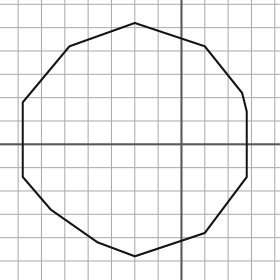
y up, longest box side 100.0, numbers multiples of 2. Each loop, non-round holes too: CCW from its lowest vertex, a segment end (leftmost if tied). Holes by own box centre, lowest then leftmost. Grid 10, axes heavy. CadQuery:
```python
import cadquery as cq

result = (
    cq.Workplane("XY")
    .moveTo(-20.0, -48.0)
    .lineTo(10.0, -38.0)
    .lineTo(28.0, -14.0)
    .lineTo(28.0, 14.0)
    .lineTo(26.0, 22.0)
    .lineTo(10.0, 42.0)
    .lineTo(-20.0, 52.0)
    .lineTo(-48.0, 42.0)
    .lineTo(-68.0, 18.0)
    .lineTo(-68.0, -14.0)
    .lineTo(-56.0, -28.0)
    .lineTo(-36.0, -42.0)
    .close()
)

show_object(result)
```